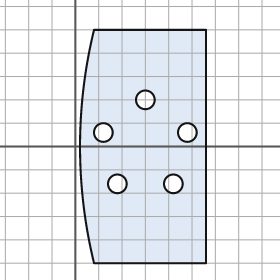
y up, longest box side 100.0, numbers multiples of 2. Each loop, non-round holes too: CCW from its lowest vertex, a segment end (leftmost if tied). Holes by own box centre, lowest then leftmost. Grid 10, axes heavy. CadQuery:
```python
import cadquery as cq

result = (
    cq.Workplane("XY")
    .moveTo(8.0, -50.0)
    .lineTo(56.0, -50.0)
    .lineTo(56.0, 50.0)
    .lineTo(8.0, 50.0)
    .threePointArc((2.0, 0.0), (8.0, -50.0))
    .close()
    .moveTo(18.0, -16.0)
    .circle(4.0)
    .moveTo(42.0, -16.0)
    .circle(4.0)
    .moveTo(12.0, 6.0)
    .circle(4.0)
    .moveTo(48.0, 6.0)
    .circle(4.0)
    .moveTo(30.0, 20.0)
    .circle(4.0)
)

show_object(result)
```